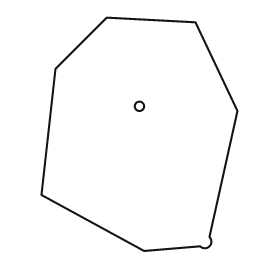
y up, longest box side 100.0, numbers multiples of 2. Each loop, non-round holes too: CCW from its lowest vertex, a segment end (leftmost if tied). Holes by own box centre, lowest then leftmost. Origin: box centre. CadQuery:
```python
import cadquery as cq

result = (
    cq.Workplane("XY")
    .moveTo(2.0, -50.0)
    .lineTo(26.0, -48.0)
    .threePointArc((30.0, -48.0), (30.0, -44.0))
    .lineTo(42.0, 10.0)
    .lineTo(24.0, 48.0)
    .lineTo(-14.0, 50.0)
    .lineTo(-36.0, 28.0)
    .lineTo(-42.0, -26.0)
    .close()
    .moveTo(0.0, 12.0)
    .circle(2.0)
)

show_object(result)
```